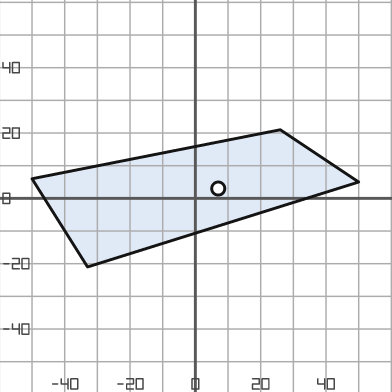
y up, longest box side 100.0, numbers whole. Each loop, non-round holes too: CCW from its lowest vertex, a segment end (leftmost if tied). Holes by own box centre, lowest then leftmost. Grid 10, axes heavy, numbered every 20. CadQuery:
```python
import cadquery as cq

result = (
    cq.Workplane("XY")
    .moveTo(-33.0, -21.0)
    .lineTo(50.0, 5.0)
    .lineTo(26.0, 21.0)
    .lineTo(-50.0, 6.0)
    .close()
    .moveTo(7.0, 3.0)
    .circle(2.0)
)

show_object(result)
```